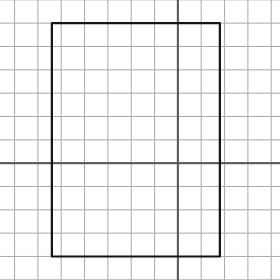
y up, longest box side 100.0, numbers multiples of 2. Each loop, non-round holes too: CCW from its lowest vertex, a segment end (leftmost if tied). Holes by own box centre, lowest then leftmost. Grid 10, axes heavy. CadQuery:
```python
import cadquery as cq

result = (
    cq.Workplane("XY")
    .moveTo(-54.0, -40.0)
    .lineTo(18.0, -40.0)
    .lineTo(18.0, 60.0)
    .lineTo(-54.0, 60.0)
    .close()
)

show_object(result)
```